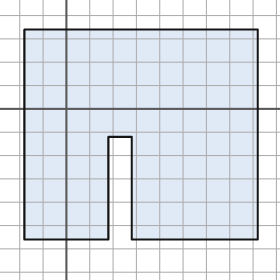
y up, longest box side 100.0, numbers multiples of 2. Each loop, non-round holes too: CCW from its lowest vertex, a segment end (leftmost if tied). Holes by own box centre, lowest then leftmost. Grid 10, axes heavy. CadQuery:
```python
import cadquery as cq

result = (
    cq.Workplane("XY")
    .moveTo(-18.0, -56.0)
    .lineTo(18.0, -56.0)
    .lineTo(18.0, -12.0)
    .lineTo(28.0, -12.0)
    .lineTo(28.0, -56.0)
    .lineTo(82.0, -56.0)
    .lineTo(82.0, 34.0)
    .lineTo(-18.0, 34.0)
    .close()
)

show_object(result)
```